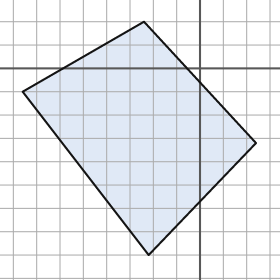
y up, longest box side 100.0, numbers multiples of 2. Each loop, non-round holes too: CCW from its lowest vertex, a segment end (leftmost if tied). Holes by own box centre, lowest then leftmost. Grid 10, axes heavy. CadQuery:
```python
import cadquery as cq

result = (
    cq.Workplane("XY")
    .moveTo(-22.0, -80.0)
    .lineTo(24.0, -32.0)
    .lineTo(-24.0, 20.0)
    .lineTo(-76.0, -10.0)
    .close()
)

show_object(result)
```